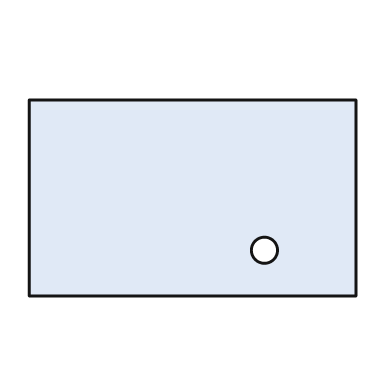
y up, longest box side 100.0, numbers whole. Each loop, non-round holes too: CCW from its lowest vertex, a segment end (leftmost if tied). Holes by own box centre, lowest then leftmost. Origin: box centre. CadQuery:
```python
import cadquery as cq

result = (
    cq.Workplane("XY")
    .moveTo(-50.0, -30.0)
    .lineTo(50.0, -30.0)
    .lineTo(50.0, 30.0)
    .lineTo(-50.0, 30.0)
    .close()
    .moveTo(22.0, -16.0)
    .circle(4.0)
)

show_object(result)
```